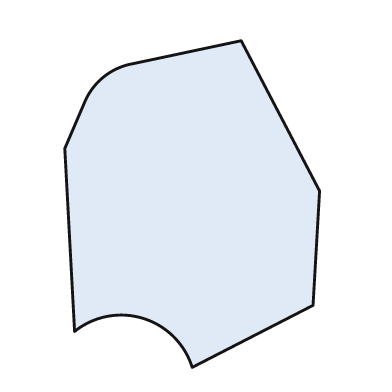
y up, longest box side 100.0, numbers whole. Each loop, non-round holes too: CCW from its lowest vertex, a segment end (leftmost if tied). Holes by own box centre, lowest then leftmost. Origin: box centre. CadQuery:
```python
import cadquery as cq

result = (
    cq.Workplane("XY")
    .moveTo(0.0, -50.0)
    .lineTo(37.0, -31.0)
    .lineTo(39.0, 4.0)
    .lineTo(15.0, 50.0)
    .lineTo(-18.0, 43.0)
    .threePointArc((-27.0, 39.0), (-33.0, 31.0))
    .lineTo(-39.0, 17.0)
    .lineTo(-36.0, -39.0)
    .threePointArc((-15.0, -35.0), (0.0, -50.0))
    .close()
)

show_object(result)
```